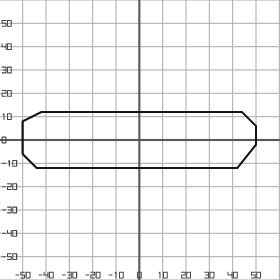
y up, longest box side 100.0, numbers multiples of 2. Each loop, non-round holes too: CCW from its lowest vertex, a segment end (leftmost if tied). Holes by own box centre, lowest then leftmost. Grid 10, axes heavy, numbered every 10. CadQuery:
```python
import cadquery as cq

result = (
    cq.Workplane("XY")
    .moveTo(-44.0, -12.0)
    .lineTo(42.0, -12.0)
    .lineTo(50.0, -2.0)
    .lineTo(50.0, 6.0)
    .lineTo(44.0, 12.0)
    .lineTo(-42.0, 12.0)
    .lineTo(-50.0, 8.0)
    .lineTo(-50.0, -6.0)
    .close()
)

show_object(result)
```